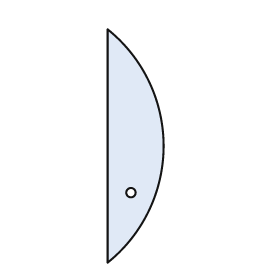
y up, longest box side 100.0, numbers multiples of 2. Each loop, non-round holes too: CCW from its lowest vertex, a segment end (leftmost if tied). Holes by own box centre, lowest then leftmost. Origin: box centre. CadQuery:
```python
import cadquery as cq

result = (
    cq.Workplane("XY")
    .moveTo(-12.0, -50.0)
    .threePointArc((12.0, 0.0), (-12.0, 50.0))
    .close()
    .moveTo(-2.0, -20.0)
    .circle(2.0)
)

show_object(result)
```